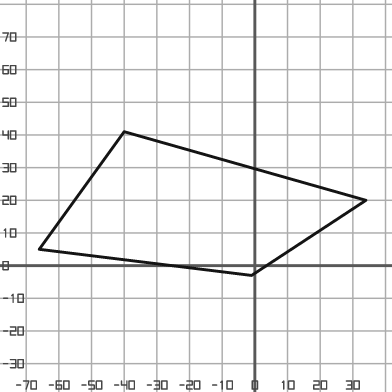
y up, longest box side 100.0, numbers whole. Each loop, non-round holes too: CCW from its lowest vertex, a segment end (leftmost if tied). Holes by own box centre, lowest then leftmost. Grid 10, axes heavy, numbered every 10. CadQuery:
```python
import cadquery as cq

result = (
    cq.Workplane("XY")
    .moveTo(-1.0, -3.0)
    .lineTo(34.0, 20.0)
    .lineTo(-40.0, 41.0)
    .lineTo(-66.0, 5.0)
    .close()
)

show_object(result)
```